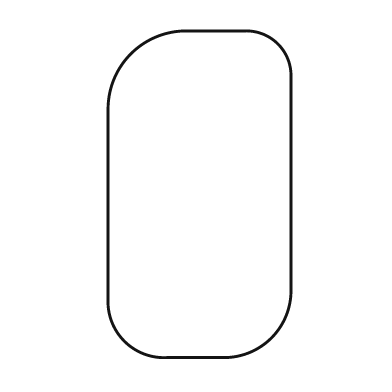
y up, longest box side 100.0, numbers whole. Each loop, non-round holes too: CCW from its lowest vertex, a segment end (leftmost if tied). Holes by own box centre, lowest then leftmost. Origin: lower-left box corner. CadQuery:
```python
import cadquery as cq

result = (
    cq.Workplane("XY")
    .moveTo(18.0, 0.0)
    .lineTo(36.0, 0.0)
    .threePointArc((50.0, 6.0), (56.0, 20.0))
    .lineTo(56.0, 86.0)
    .threePointArc((52.0, 96.0), (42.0, 100.0))
    .lineTo(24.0, 100.0)
    .threePointArc((7.0, 93.0), (0.0, 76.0))
    .lineTo(0.0, 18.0)
    .threePointArc((5.0, 5.0), (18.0, 0.0))
    .close()
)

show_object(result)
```